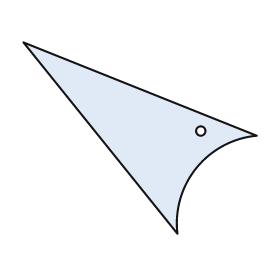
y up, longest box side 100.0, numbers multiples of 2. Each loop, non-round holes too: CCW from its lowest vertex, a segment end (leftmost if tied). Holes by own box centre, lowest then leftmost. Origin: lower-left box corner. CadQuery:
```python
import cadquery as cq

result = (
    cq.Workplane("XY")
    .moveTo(66.0, 0.0)
    .threePointArc((74.0, 28.0), (100.0, 42.0))
    .lineTo(0.0, 82.0)
    .close()
    .moveTo(76.0, 44.0)
    .circle(2.0)
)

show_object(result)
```